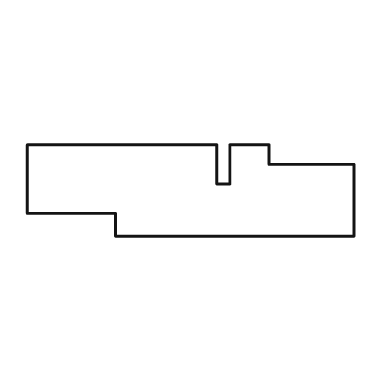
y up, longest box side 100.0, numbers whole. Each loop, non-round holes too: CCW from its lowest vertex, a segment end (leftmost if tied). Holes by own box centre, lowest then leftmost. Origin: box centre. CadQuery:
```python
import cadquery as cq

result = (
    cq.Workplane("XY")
    .moveTo(-23.0, -14.0)
    .lineTo(50.0, -14.0)
    .lineTo(50.0, 8.0)
    .lineTo(24.0, 8.0)
    .lineTo(24.0, 14.0)
    .lineTo(12.0, 14.0)
    .lineTo(12.0, 2.0)
    .lineTo(8.0, 2.0)
    .lineTo(8.0, 14.0)
    .lineTo(-50.0, 14.0)
    .lineTo(-50.0, -7.0)
    .lineTo(-23.0, -7.0)
    .close()
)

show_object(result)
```